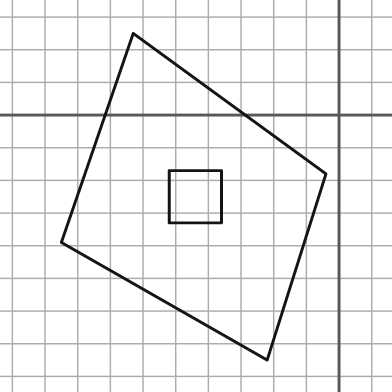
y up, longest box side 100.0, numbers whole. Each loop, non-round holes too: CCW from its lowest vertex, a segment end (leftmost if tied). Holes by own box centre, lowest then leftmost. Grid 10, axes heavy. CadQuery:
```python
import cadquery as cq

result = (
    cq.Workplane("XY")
    .moveTo(-22.0, -75.0)
    .lineTo(-4.0, -18.0)
    .lineTo(-63.0, 25.0)
    .lineTo(-85.0, -39.0)
    .close()
    .moveTo(-52.0, -33.0)
    .lineTo(-36.0, -33.0)
    .lineTo(-36.0, -17.0)
    .lineTo(-52.0, -17.0)
    .close()
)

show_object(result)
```